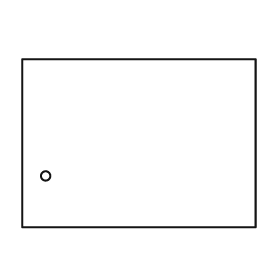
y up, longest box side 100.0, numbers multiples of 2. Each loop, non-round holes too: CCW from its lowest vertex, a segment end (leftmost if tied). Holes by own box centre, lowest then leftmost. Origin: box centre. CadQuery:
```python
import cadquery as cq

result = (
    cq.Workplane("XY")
    .moveTo(-50.0, -36.0)
    .lineTo(50.0, -36.0)
    .lineTo(50.0, 36.0)
    .lineTo(-50.0, 36.0)
    .close()
    .moveTo(-40.0, -14.0)
    .circle(2.0)
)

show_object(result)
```